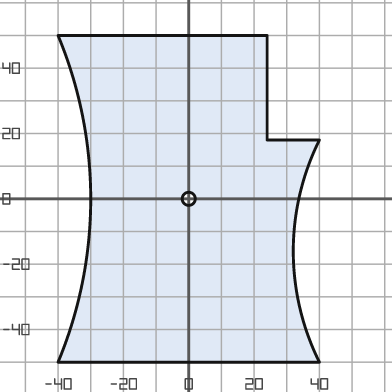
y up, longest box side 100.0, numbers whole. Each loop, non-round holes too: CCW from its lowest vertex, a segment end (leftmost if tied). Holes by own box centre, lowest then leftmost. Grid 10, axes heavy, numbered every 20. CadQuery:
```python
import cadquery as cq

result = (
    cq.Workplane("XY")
    .moveTo(-40.0, -50.0)
    .lineTo(40.0, -50.0)
    .threePointArc((32.0, -16.0), (40.0, 18.0))
    .lineTo(24.0, 18.0)
    .lineTo(24.0, 50.0)
    .lineTo(-40.0, 50.0)
    .threePointArc((-30.0, 0.0), (-40.0, -50.0))
    .close()
    .moveTo(0.0, 0.0)
    .circle(2.0)
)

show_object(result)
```